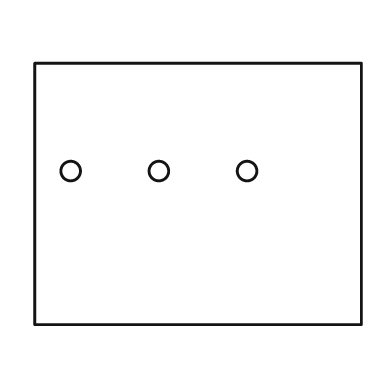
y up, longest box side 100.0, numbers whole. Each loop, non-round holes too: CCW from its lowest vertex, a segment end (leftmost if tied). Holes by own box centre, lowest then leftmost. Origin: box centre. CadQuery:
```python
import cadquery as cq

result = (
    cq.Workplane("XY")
    .moveTo(-50.0, -40.0)
    .lineTo(50.0, -40.0)
    .lineTo(50.0, 40.0)
    .lineTo(-50.0, 40.0)
    .close()
    .moveTo(-39.0, 7.0)
    .circle(3.0)
    .moveTo(-12.0, 7.0)
    .circle(3.0)
    .moveTo(15.0, 7.0)
    .circle(3.0)
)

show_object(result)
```